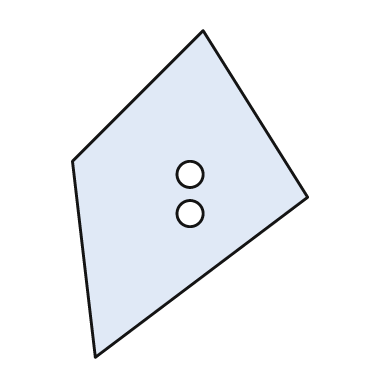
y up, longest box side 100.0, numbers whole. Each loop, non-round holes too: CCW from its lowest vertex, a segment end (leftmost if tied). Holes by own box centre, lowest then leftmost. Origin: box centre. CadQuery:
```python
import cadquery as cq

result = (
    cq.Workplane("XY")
    .moveTo(-29.0, -50.0)
    .lineTo(36.0, -1.0)
    .lineTo(4.0, 50.0)
    .lineTo(-36.0, 10.0)
    .close()
    .moveTo(0.0, -6.0)
    .circle(4.0)
    .moveTo(0.0, 6.0)
    .circle(4.0)
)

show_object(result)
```